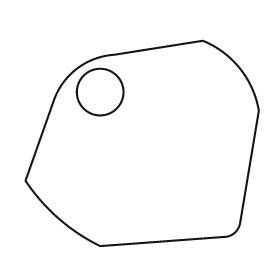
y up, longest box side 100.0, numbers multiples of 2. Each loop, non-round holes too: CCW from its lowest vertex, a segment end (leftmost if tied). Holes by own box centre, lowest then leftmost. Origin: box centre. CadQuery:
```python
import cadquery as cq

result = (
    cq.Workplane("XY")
    .moveTo(-18.0, -44.0)
    .lineTo(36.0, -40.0)
    .threePointArc((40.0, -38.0), (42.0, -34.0))
    .lineTo(50.0, 14.0)
    .threePointArc((42.0, 32.0), (26.0, 44.0))
    .lineTo(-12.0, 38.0)
    .threePointArc((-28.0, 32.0), (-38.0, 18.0))
    .lineTo(-50.0, -16.0)
    .threePointArc((-36.0, -32.0), (-18.0, -44.0))
    .close()
    .moveTo(-18.0, 22.0)
    .circle(10.0)
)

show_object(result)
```